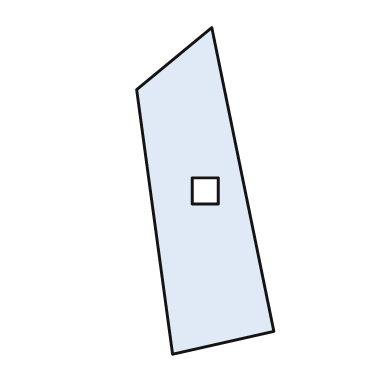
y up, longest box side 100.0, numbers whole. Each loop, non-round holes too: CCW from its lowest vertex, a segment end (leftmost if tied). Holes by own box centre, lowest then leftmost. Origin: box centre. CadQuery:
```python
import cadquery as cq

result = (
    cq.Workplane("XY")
    .moveTo(-10.0, -50.0)
    .lineTo(21.0, -43.0)
    .lineTo(2.0, 50.0)
    .lineTo(-21.0, 31.0)
    .close()
    .moveTo(-4.0, -4.0)
    .lineTo(4.0, -4.0)
    .lineTo(4.0, 4.0)
    .lineTo(-4.0, 4.0)
    .close()
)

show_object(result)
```